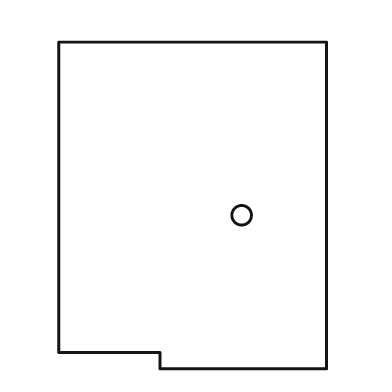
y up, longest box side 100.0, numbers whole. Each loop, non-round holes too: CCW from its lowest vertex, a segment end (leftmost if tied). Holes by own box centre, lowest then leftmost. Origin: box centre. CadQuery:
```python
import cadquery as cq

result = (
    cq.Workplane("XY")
    .moveTo(-10.0, -50.0)
    .lineTo(41.0, -50.0)
    .lineTo(41.0, 50.0)
    .lineTo(-41.0, 50.0)
    .lineTo(-41.0, -45.0)
    .lineTo(-10.0, -45.0)
    .close()
    .moveTo(15.0, -3.0)
    .circle(3.0)
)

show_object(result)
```